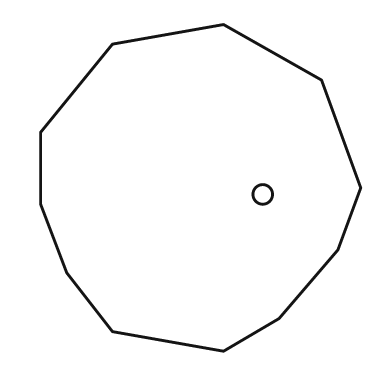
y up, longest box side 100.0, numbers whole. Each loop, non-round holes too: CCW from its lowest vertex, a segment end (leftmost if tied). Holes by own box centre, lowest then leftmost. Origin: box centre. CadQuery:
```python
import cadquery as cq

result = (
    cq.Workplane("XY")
    .moveTo(7.0, -50.0)
    .lineTo(24.0, -40.0)
    .lineTo(42.0, -19.0)
    .lineTo(49.0, 0.0)
    .lineTo(37.0, 33.0)
    .lineTo(7.0, 50.0)
    .lineTo(-27.0, 44.0)
    .lineTo(-49.0, 17.0)
    .lineTo(-49.0, -5.0)
    .lineTo(-41.0, -26.0)
    .lineTo(-27.0, -44.0)
    .close()
    .moveTo(19.0, -2.0)
    .circle(3.0)
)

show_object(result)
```